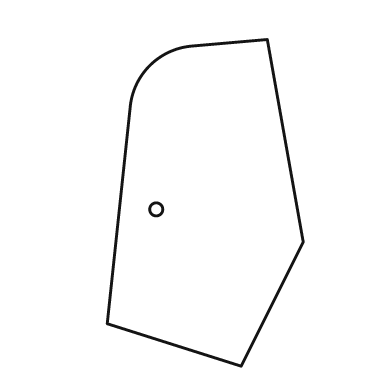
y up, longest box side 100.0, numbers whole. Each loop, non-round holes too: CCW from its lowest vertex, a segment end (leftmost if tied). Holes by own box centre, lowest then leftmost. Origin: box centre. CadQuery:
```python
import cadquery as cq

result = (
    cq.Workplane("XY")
    .moveTo(11.0, -50.0)
    .lineTo(30.0, -12.0)
    .lineTo(19.0, 50.0)
    .lineTo(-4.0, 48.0)
    .threePointArc((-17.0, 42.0), (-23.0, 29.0))
    .lineTo(-30.0, -37.0)
    .close()
    .moveTo(-15.0, -2.0)
    .circle(2.0)
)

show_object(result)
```